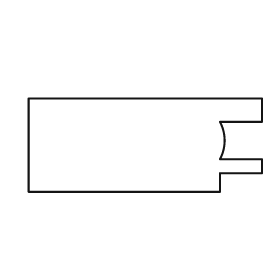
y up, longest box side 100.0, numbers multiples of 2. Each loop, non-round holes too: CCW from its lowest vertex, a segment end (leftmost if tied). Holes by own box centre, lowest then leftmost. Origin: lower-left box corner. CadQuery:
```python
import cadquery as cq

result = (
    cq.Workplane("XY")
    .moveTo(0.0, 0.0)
    .lineTo(82.0, 0.0)
    .lineTo(82.0, 8.0)
    .lineTo(100.0, 8.0)
    .lineTo(100.0, 14.0)
    .lineTo(82.0, 14.0)
    .threePointArc((84.0, 22.0), (82.0, 30.0))
    .lineTo(100.0, 30.0)
    .lineTo(100.0, 40.0)
    .lineTo(0.0, 40.0)
    .close()
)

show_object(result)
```